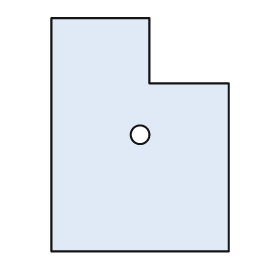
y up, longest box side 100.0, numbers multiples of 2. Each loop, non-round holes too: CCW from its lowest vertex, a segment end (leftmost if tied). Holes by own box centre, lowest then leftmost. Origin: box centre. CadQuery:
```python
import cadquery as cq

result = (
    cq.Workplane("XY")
    .moveTo(-38.0, -50.0)
    .lineTo(38.0, -50.0)
    .lineTo(38.0, 22.0)
    .lineTo(4.0, 22.0)
    .lineTo(4.0, 50.0)
    .lineTo(-38.0, 50.0)
    .close()
    .moveTo(0.0, 0.0)
    .circle(4.0)
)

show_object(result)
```